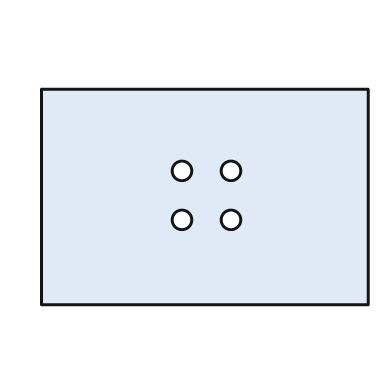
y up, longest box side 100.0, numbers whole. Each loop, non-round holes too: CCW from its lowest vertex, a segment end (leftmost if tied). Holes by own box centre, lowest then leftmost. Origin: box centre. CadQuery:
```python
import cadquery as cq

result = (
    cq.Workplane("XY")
    .moveTo(-50.0, -33.0)
    .lineTo(50.0, -33.0)
    .lineTo(50.0, 33.0)
    .lineTo(-50.0, 33.0)
    .close()
    .moveTo(-7.0, -7.0)
    .circle(3.0)
    .moveTo(8.0, -7.0)
    .circle(3.0)
    .moveTo(-7.0, 8.0)
    .circle(3.0)
    .moveTo(8.0, 8.0)
    .circle(3.0)
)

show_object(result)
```